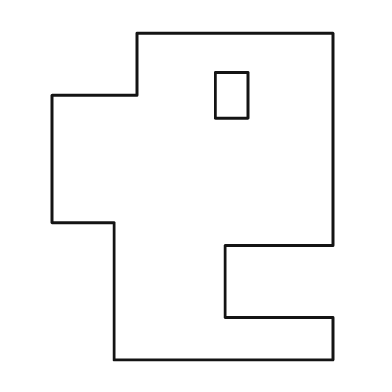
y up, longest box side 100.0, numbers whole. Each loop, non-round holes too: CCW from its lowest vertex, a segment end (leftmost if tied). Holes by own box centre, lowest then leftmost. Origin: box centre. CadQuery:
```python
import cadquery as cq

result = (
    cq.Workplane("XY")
    .moveTo(-24.0, -50.0)
    .lineTo(43.0, -50.0)
    .lineTo(43.0, -37.0)
    .lineTo(10.0, -37.0)
    .lineTo(10.0, -15.0)
    .lineTo(43.0, -15.0)
    .lineTo(43.0, 50.0)
    .lineTo(-17.0, 50.0)
    .lineTo(-17.0, 31.0)
    .lineTo(-43.0, 31.0)
    .lineTo(-43.0, -8.0)
    .lineTo(-24.0, -8.0)
    .close()
    .moveTo(7.0, 24.0)
    .lineTo(17.0, 24.0)
    .lineTo(17.0, 38.0)
    .lineTo(7.0, 38.0)
    .close()
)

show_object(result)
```